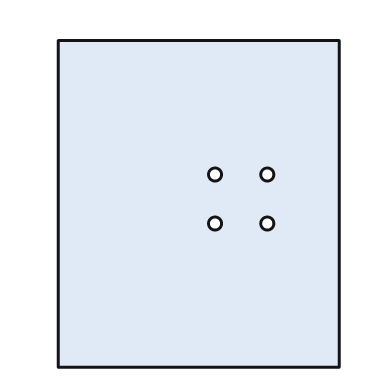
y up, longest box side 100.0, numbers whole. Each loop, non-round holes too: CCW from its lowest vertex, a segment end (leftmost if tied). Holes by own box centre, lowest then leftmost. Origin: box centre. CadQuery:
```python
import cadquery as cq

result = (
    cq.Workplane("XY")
    .moveTo(-43.0, -50.0)
    .lineTo(43.0, -50.0)
    .lineTo(43.0, 50.0)
    .lineTo(-43.0, 50.0)
    .close()
    .moveTo(5.0, -6.0)
    .circle(2.0)
    .moveTo(21.0, -6.0)
    .circle(2.0)
    .moveTo(5.0, 9.0)
    .circle(2.0)
    .moveTo(21.0, 9.0)
    .circle(2.0)
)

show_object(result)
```